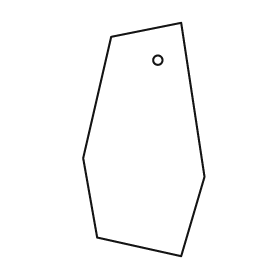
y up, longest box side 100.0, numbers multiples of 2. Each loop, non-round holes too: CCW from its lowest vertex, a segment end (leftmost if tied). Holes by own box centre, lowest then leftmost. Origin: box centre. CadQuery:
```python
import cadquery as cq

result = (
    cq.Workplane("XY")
    .moveTo(16.0, -50.0)
    .lineTo(26.0, -16.0)
    .lineTo(16.0, 50.0)
    .lineTo(-14.0, 44.0)
    .lineTo(-26.0, -8.0)
    .lineTo(-20.0, -42.0)
    .close()
    .moveTo(6.0, 34.0)
    .circle(2.0)
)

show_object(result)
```